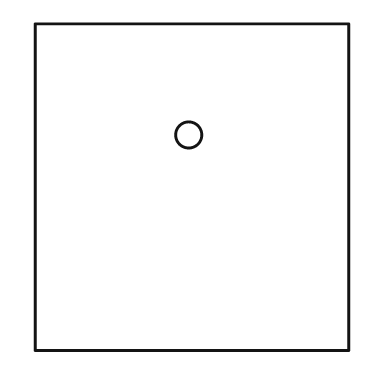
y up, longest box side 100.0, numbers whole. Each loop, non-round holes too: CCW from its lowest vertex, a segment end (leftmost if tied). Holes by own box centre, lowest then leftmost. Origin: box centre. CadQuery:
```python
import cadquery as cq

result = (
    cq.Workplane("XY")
    .moveTo(-48.0, -50.0)
    .lineTo(48.0, -50.0)
    .lineTo(48.0, 50.0)
    .lineTo(-48.0, 50.0)
    .close()
    .moveTo(-1.0, 16.0)
    .circle(4.0)
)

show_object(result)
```